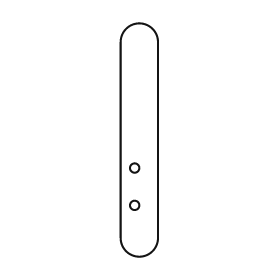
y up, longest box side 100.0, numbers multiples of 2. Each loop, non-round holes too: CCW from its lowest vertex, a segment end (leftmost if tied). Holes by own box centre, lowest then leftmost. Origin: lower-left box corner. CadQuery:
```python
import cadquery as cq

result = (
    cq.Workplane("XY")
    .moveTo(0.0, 8.0)
    .threePointArc((8.0, 0.0), (16.0, 8.0))
    .lineTo(16.0, 92.0)
    .threePointArc((8.0, 100.0), (0.0, 92.0))
    .close()
    .moveTo(6.0, 22.0)
    .circle(2.0)
    .moveTo(6.0, 38.0)
    .circle(2.0)
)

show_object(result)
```